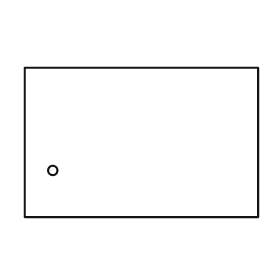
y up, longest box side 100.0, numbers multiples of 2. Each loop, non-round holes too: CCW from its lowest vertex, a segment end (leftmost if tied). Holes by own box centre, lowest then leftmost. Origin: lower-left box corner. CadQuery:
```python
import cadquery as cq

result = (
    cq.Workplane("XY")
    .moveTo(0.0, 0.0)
    .lineTo(100.0, 0.0)
    .lineTo(100.0, 64.0)
    .lineTo(0.0, 64.0)
    .close()
    .moveTo(12.0, 20.0)
    .circle(2.0)
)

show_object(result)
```